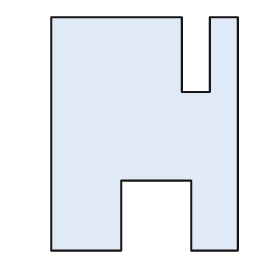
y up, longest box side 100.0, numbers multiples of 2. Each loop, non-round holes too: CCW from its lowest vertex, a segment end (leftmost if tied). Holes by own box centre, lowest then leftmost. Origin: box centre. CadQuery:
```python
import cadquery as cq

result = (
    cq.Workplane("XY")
    .moveTo(-40.0, -50.0)
    .lineTo(-10.0, -50.0)
    .lineTo(-10.0, -20.0)
    .lineTo(20.0, -20.0)
    .lineTo(20.0, -50.0)
    .lineTo(40.0, -50.0)
    .lineTo(40.0, 50.0)
    .lineTo(28.0, 50.0)
    .lineTo(28.0, 18.0)
    .lineTo(16.0, 18.0)
    .lineTo(16.0, 50.0)
    .lineTo(-40.0, 50.0)
    .close()
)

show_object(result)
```